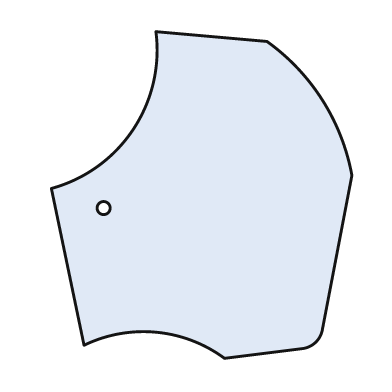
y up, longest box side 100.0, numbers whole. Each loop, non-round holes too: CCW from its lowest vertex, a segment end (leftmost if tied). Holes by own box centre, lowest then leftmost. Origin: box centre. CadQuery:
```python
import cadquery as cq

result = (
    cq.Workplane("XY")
    .moveTo(7.0, -50.0)
    .lineTo(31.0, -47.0)
    .threePointArc((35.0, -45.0), (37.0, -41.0))
    .lineTo(46.0, 6.0)
    .threePointArc((37.0, 29.0), (20.0, 47.0))
    .lineTo(-14.0, 50.0)
    .threePointArc((-21.0, 20.0), (-46.0, 2.0))
    .lineTo(-36.0, -46.0)
    .threePointArc((-14.0, -42.0), (7.0, -50.0))
    .close()
    .moveTo(-30.0, -4.0)
    .circle(2.0)
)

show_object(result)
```